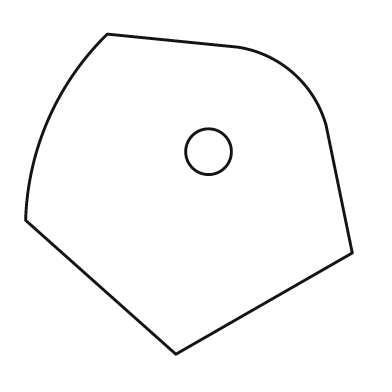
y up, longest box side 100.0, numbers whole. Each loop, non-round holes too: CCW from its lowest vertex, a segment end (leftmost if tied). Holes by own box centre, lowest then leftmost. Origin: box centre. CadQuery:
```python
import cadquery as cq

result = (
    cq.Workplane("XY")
    .moveTo(-4.0, -49.0)
    .lineTo(50.0, -18.0)
    .lineTo(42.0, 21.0)
    .threePointArc((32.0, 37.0), (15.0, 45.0))
    .lineTo(-25.0, 49.0)
    .threePointArc((-43.0, 23.0), (-50.0, -8.0))
    .close()
    .moveTo(6.0, 13.0)
    .circle(7.0)
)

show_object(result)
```